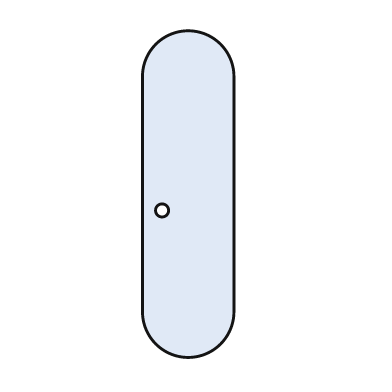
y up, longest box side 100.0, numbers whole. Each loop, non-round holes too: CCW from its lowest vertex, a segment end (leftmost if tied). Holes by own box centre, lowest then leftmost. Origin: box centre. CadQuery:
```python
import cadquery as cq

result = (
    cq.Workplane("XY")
    .moveTo(-14.0, -36.0)
    .threePointArc((0.0, -50.0), (14.0, -36.0))
    .lineTo(14.0, 36.0)
    .threePointArc((0.0, 50.0), (-14.0, 36.0))
    .close()
    .moveTo(-8.0, -5.0)
    .circle(2.0)
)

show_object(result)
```